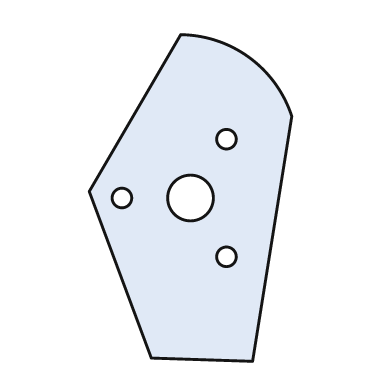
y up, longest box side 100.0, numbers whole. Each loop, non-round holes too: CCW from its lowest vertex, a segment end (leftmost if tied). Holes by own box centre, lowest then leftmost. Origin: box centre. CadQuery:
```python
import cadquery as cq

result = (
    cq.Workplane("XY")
    .moveTo(19.0, -50.0)
    .lineTo(31.0, 25.0)
    .threePointArc((18.0, 43.0), (-3.0, 50.0))
    .lineTo(-31.0, 2.0)
    .lineTo(-12.0, -49.0)
    .close()
    .moveTo(11.0, -18.0)
    .circle(3.0)
    .moveTo(-21.0, 0.0)
    .circle(3.0)
    .moveTo(0.0, 0.0)
    .circle(7.0)
    .moveTo(11.0, 18.0)
    .circle(3.0)
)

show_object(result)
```